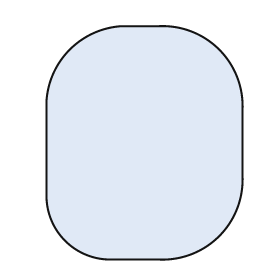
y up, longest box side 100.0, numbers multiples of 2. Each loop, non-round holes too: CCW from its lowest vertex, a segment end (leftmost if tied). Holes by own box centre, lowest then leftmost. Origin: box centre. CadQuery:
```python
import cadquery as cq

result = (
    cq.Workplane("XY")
    .moveTo(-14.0, -50.0)
    .lineTo(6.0, -50.0)
    .threePointArc((32.0, -40.0), (42.0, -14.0))
    .lineTo(42.0, 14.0)
    .threePointArc((32.0, 40.0), (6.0, 50.0))
    .lineTo(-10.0, 50.0)
    .threePointArc((-32.0, 40.0), (-42.0, 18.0))
    .lineTo(-42.0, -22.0)
    .threePointArc((-34.0, -42.0), (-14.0, -50.0))
    .close()
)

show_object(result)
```